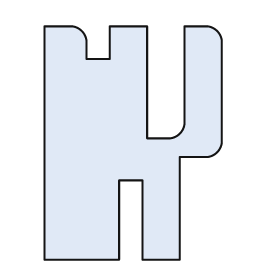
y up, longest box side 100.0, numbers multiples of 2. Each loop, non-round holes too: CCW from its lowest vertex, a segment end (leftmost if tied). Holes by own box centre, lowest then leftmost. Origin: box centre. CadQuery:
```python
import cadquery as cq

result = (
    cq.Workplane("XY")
    .moveTo(-38.0, -50.0)
    .lineTo(-6.0, -50.0)
    .lineTo(-6.0, -16.0)
    .lineTo(4.0, -16.0)
    .lineTo(4.0, -50.0)
    .lineTo(20.0, -50.0)
    .lineTo(20.0, -6.0)
    .lineTo(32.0, -6.0)
    .threePointArc((36.0, -4.0), (38.0, 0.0))
    .lineTo(38.0, 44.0)
    .threePointArc((36.0, 48.0), (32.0, 50.0))
    .lineTo(22.0, 50.0)
    .lineTo(22.0, 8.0)
    .threePointArc((20.0, 4.0), (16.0, 2.0))
    .lineTo(6.0, 2.0)
    .lineTo(6.0, 50.0)
    .lineTo(-10.0, 50.0)
    .lineTo(-10.0, 36.0)
    .lineTo(-20.0, 36.0)
    .lineTo(-20.0, 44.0)
    .threePointArc((-22.0, 48.0), (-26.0, 50.0))
    .lineTo(-38.0, 50.0)
    .close()
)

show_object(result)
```